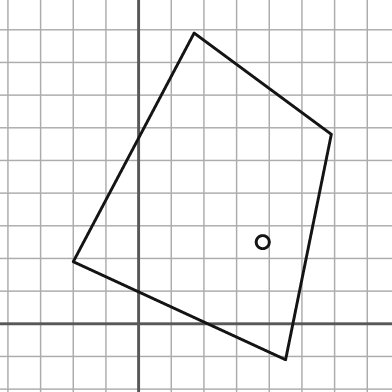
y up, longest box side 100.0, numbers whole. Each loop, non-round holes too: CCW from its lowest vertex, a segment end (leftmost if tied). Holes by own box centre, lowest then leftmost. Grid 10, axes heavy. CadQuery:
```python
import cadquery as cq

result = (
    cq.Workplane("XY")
    .moveTo(45.0, -11.0)
    .lineTo(59.0, 58.0)
    .lineTo(17.0, 89.0)
    .lineTo(-20.0, 19.0)
    .close()
    .moveTo(38.0, 25.0)
    .circle(2.0)
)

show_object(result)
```